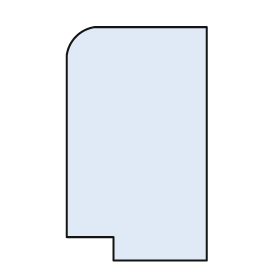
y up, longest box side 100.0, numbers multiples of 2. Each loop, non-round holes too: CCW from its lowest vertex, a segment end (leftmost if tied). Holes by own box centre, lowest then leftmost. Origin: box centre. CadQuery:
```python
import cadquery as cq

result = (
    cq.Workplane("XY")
    .moveTo(-10.0, -50.0)
    .lineTo(30.0, -50.0)
    .lineTo(30.0, 50.0)
    .lineTo(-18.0, 50.0)
    .threePointArc((-26.0, 46.0), (-30.0, 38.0))
    .lineTo(-30.0, -40.0)
    .lineTo(-10.0, -40.0)
    .close()
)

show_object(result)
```